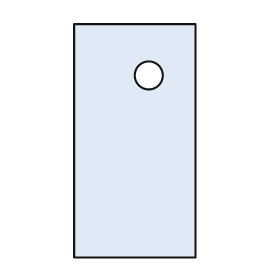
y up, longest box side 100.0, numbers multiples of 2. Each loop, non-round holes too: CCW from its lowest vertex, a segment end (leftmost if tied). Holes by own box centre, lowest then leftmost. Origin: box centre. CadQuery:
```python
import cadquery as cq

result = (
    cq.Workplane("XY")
    .moveTo(-26.0, -50.0)
    .lineTo(26.0, -50.0)
    .lineTo(26.0, 50.0)
    .lineTo(-26.0, 50.0)
    .close()
    .moveTo(6.0, 28.0)
    .circle(6.0)
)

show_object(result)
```